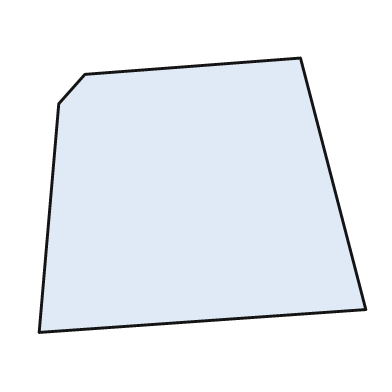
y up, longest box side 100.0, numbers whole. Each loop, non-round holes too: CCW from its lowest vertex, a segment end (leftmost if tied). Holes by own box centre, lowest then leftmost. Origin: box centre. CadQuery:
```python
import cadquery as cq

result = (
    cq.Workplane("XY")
    .moveTo(-50.0, -42.0)
    .lineTo(50.0, -35.0)
    .lineTo(30.0, 42.0)
    .lineTo(-36.0, 37.0)
    .lineTo(-44.0, 28.0)
    .close()
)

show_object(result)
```